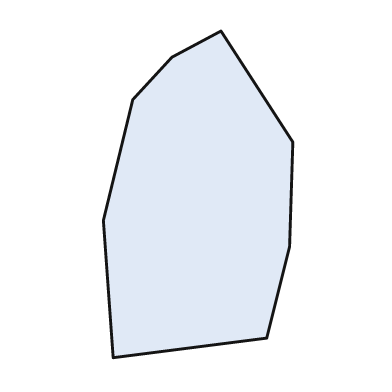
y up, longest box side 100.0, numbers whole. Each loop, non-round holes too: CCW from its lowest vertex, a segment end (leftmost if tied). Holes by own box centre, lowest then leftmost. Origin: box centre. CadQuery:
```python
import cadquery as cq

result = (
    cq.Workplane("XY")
    .moveTo(-26.0, -50.0)
    .lineTo(21.0, -44.0)
    .lineTo(28.0, -16.0)
    .lineTo(29.0, 16.0)
    .lineTo(7.0, 50.0)
    .lineTo(-8.0, 42.0)
    .lineTo(-20.0, 29.0)
    .lineTo(-29.0, -8.0)
    .close()
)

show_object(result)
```